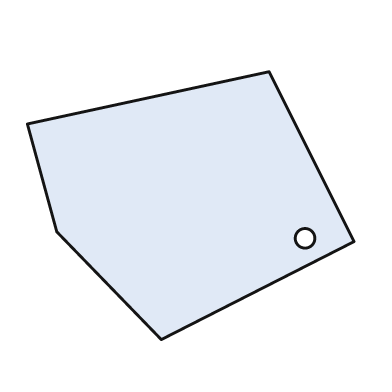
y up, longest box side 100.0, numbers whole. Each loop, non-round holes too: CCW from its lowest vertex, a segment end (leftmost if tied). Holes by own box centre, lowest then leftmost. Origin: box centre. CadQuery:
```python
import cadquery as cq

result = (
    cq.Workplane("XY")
    .moveTo(-9.0, -41.0)
    .lineTo(50.0, -11.0)
    .lineTo(24.0, 41.0)
    .lineTo(-50.0, 25.0)
    .lineTo(-41.0, -8.0)
    .close()
    .moveTo(35.0, -10.0)
    .circle(3.0)
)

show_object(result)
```